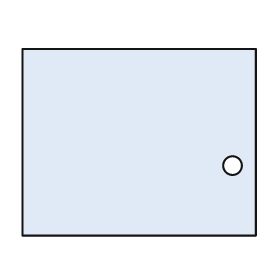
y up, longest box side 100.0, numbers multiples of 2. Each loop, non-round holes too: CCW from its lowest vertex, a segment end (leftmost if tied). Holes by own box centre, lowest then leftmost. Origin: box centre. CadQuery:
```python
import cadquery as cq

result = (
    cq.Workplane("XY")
    .moveTo(-50.0, -40.0)
    .lineTo(50.0, -40.0)
    .lineTo(50.0, 40.0)
    .lineTo(-50.0, 40.0)
    .close()
    .moveTo(40.0, -10.0)
    .circle(4.0)
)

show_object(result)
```